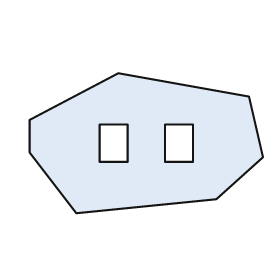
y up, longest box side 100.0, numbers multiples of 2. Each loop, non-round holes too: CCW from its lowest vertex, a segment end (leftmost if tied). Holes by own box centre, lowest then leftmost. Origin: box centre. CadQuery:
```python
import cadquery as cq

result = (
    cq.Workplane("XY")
    .moveTo(-30.0, -30.0)
    .lineTo(30.0, -24.0)
    .lineTo(50.0, -6.0)
    .lineTo(44.0, 20.0)
    .lineTo(-12.0, 30.0)
    .lineTo(-50.0, 10.0)
    .lineTo(-50.0, -4.0)
    .close()
    .moveTo(-20.0, -8.0)
    .lineTo(-8.0, -8.0)
    .lineTo(-8.0, 8.0)
    .lineTo(-20.0, 8.0)
    .close()
    .moveTo(8.0, -8.0)
    .lineTo(20.0, -8.0)
    .lineTo(20.0, 8.0)
    .lineTo(8.0, 8.0)
    .close()
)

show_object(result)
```